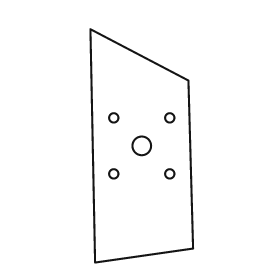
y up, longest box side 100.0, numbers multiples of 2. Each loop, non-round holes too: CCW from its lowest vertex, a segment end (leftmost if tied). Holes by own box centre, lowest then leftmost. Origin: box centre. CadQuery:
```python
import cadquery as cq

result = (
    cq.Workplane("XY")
    .moveTo(-20.0, -50.0)
    .lineTo(22.0, -44.0)
    .lineTo(20.0, 28.0)
    .lineTo(-22.0, 50.0)
    .close()
    .moveTo(-12.0, -12.0)
    .circle(2.0)
    .moveTo(12.0, -12.0)
    .circle(2.0)
    .moveTo(0.0, 0.0)
    .circle(4.0)
    .moveTo(-12.0, 12.0)
    .circle(2.0)
    .moveTo(12.0, 12.0)
    .circle(2.0)
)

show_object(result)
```